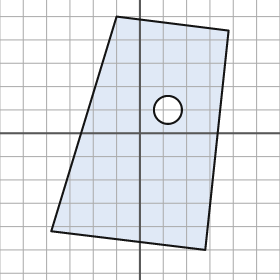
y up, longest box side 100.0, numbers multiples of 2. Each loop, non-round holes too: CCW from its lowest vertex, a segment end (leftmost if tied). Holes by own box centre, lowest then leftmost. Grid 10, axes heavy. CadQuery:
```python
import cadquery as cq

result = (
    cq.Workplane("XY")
    .moveTo(28.0, -50.0)
    .lineTo(38.0, 44.0)
    .lineTo(-10.0, 50.0)
    .lineTo(-38.0, -42.0)
    .close()
    .moveTo(12.0, 10.0)
    .circle(6.0)
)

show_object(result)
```